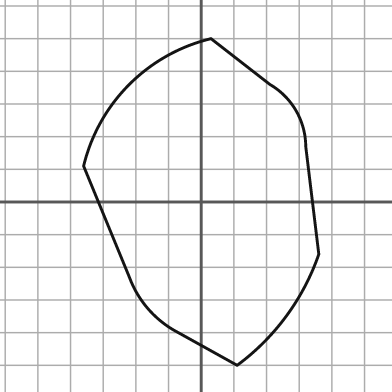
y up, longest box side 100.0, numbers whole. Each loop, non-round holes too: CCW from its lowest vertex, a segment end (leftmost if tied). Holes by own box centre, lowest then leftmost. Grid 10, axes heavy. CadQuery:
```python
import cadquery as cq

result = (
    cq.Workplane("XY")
    .moveTo(11.0, -50.0)
    .threePointArc((26.0, -35.0), (36.0, -16.0))
    .lineTo(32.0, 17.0)
    .threePointArc((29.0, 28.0), (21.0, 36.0))
    .lineTo(3.0, 50.0)
    .threePointArc((-22.0, 36.0), (-36.0, 11.0))
    .lineTo(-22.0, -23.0)
    .threePointArc((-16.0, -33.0), (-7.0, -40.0))
    .close()
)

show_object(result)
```